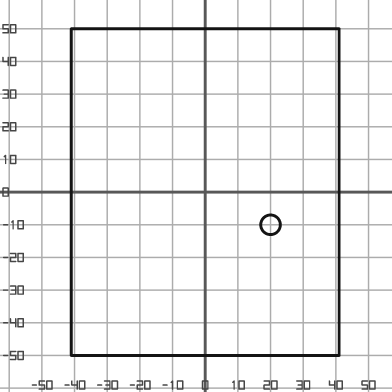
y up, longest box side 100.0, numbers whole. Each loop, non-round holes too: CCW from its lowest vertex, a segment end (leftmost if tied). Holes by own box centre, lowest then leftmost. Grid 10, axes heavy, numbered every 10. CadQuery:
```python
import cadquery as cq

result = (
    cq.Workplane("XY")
    .moveTo(-41.0, -50.0)
    .lineTo(41.0, -50.0)
    .lineTo(41.0, 50.0)
    .lineTo(-41.0, 50.0)
    .close()
    .moveTo(20.0, -10.0)
    .circle(3.0)
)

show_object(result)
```